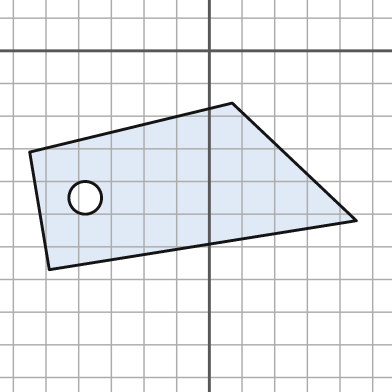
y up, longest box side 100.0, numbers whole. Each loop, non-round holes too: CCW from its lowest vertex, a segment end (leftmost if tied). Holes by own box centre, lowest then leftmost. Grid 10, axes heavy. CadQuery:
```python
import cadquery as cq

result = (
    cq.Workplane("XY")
    .moveTo(-49.0, -67.0)
    .lineTo(45.0, -52.0)
    .lineTo(7.0, -16.0)
    .lineTo(-55.0, -31.0)
    .close()
    .moveTo(-38.0, -45.0)
    .circle(5.0)
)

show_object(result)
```